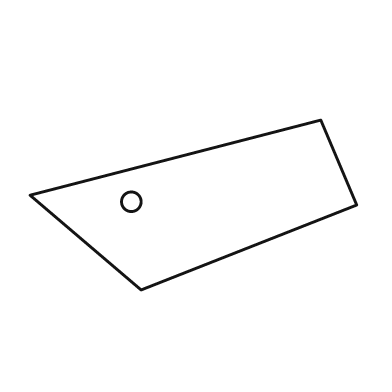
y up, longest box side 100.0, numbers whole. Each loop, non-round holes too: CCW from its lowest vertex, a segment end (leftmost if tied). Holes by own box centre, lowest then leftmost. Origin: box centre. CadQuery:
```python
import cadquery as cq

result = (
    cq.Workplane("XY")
    .moveTo(-16.0, -26.0)
    .lineTo(50.0, 0.0)
    .lineTo(39.0, 26.0)
    .lineTo(-50.0, 3.0)
    .close()
    .moveTo(-19.0, 1.0)
    .circle(3.0)
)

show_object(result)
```